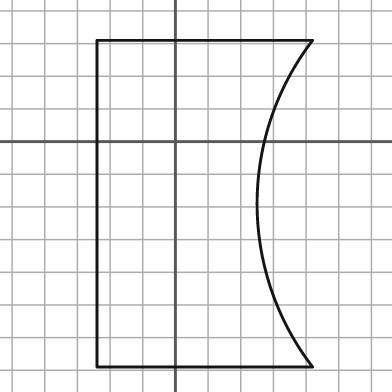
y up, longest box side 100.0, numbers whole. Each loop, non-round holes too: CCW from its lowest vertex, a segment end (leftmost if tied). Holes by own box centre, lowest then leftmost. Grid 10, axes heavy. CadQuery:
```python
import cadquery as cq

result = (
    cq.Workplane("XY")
    .moveTo(-24.0, -69.0)
    .lineTo(42.0, -69.0)
    .threePointArc((25.0, -19.0), (42.0, 31.0))
    .lineTo(-24.0, 31.0)
    .close()
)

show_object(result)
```